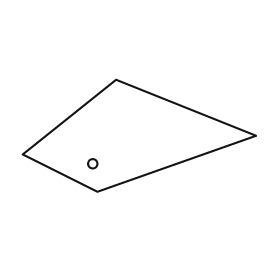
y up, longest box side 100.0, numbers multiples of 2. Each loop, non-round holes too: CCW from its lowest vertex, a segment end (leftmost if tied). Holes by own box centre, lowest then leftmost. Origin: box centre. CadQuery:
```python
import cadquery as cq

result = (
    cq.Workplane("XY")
    .moveTo(-18.0, -24.0)
    .lineTo(50.0, 0.0)
    .lineTo(-10.0, 24.0)
    .lineTo(-50.0, -8.0)
    .close()
    .moveTo(-20.0, -12.0)
    .circle(2.0)
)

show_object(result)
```